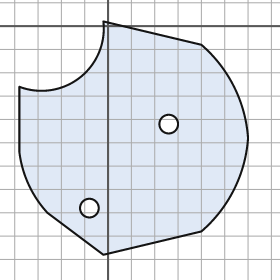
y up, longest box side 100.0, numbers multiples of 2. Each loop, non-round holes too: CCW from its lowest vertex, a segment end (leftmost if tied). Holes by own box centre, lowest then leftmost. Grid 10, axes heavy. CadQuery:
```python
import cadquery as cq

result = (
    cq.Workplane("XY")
    .moveTo(-2.0, -98.0)
    .lineTo(40.0, -88.0)
    .threePointArc((54.0, -70.0), (60.0, -48.0))
    .threePointArc((54.0, -26.0), (40.0, -8.0))
    .lineTo(-2.0, 2.0)
    .threePointArc((-12.0, -22.0), (-38.0, -26.0))
    .lineTo(-38.0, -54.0)
    .threePointArc((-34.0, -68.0), (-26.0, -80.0))
    .close()
    .moveTo(-8.0, -78.0)
    .circle(4.0)
    .moveTo(26.0, -42.0)
    .circle(4.0)
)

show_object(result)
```